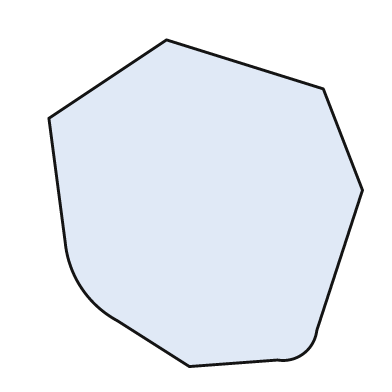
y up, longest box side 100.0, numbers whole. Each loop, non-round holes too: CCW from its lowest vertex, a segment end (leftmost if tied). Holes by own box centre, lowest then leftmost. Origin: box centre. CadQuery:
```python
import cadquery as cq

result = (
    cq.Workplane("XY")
    .moveTo(-5.0, -50.0)
    .lineTo(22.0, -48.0)
    .threePointArc((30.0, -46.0), (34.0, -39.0))
    .lineTo(48.0, 4.0)
    .lineTo(36.0, 35.0)
    .lineTo(-12.0, 50.0)
    .lineTo(-48.0, 26.0)
    .lineTo(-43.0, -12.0)
    .threePointArc((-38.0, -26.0), (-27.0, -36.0))
    .close()
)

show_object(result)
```